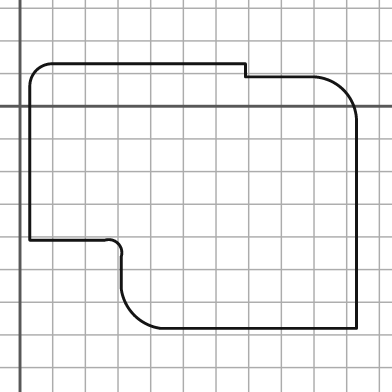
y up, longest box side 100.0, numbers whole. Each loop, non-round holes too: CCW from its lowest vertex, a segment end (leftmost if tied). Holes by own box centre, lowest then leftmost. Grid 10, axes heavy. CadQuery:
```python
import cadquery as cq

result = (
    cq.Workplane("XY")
    .moveTo(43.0, -68.0)
    .lineTo(103.0, -68.0)
    .lineTo(103.0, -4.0)
    .threePointArc((99.0, 5.0), (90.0, 9.0))
    .lineTo(69.0, 9.0)
    .lineTo(69.0, 13.0)
    .lineTo(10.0, 13.0)
    .threePointArc((5.0, 11.0), (3.0, 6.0))
    .lineTo(3.0, -41.0)
    .lineTo(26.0, -41.0)
    .threePointArc((30.0, -42.0), (31.0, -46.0))
    .lineTo(31.0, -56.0)
    .threePointArc((35.0, -64.0), (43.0, -68.0))
    .close()
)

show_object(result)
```